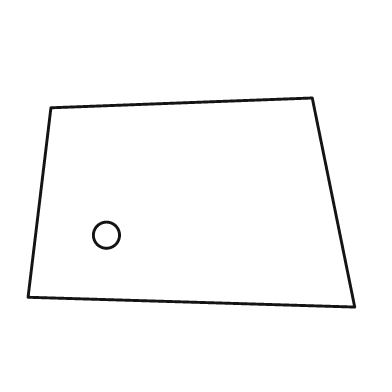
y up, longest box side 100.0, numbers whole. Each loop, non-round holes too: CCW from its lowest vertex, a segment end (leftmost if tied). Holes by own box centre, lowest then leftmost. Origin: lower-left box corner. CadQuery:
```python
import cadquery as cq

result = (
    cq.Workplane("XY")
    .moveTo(100.0, 0.0)
    .lineTo(87.0, 64.0)
    .lineTo(7.0, 61.0)
    .lineTo(0.0, 3.0)
    .close()
    .moveTo(24.0, 22.0)
    .circle(4.0)
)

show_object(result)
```